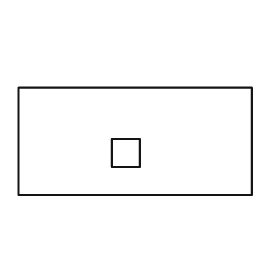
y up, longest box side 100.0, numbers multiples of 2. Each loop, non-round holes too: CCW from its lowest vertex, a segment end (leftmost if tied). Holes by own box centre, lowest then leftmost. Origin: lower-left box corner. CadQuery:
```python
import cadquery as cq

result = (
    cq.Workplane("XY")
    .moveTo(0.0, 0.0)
    .lineTo(100.0, 0.0)
    .lineTo(100.0, 46.0)
    .lineTo(0.0, 46.0)
    .close()
    .moveTo(40.0, 12.0)
    .lineTo(52.0, 12.0)
    .lineTo(52.0, 24.0)
    .lineTo(40.0, 24.0)
    .close()
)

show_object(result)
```